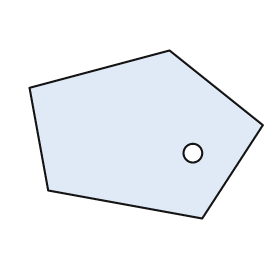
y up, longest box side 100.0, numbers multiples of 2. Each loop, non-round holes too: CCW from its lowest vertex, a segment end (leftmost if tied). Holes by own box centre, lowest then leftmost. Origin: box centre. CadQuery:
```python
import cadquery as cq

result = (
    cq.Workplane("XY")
    .moveTo(24.0, -36.0)
    .lineTo(50.0, 4.0)
    .lineTo(10.0, 36.0)
    .lineTo(-50.0, 20.0)
    .lineTo(-42.0, -24.0)
    .close()
    .moveTo(20.0, -8.0)
    .circle(4.0)
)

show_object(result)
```